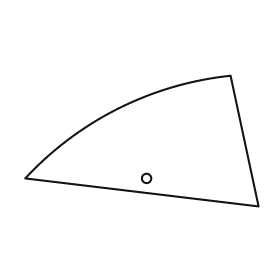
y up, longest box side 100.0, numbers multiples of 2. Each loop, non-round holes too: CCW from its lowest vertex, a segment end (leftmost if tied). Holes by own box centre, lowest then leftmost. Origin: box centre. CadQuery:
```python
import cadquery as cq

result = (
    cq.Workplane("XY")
    .moveTo(50.0, -28.0)
    .lineTo(38.0, 28.0)
    .threePointArc((-10.0, 14.0), (-50.0, -16.0))
    .close()
    .moveTo(2.0, -16.0)
    .circle(2.0)
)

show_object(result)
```